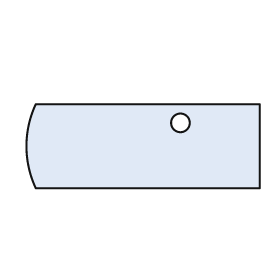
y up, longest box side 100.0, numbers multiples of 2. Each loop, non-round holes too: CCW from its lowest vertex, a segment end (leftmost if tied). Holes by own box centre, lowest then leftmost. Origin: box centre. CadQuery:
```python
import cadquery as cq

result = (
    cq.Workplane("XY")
    .moveTo(-46.0, -18.0)
    .lineTo(50.0, -18.0)
    .lineTo(50.0, 18.0)
    .lineTo(-46.0, 18.0)
    .threePointArc((-50.0, 0.0), (-46.0, -18.0))
    .close()
    .moveTo(16.0, 10.0)
    .circle(4.0)
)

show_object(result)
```